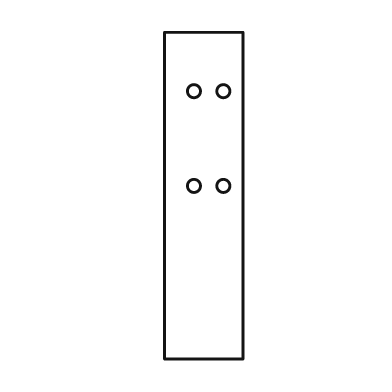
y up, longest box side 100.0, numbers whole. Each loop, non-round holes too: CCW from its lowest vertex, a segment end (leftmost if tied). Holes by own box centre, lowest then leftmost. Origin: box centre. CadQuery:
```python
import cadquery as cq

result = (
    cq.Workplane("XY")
    .moveTo(-12.0, -50.0)
    .lineTo(12.0, -50.0)
    .lineTo(12.0, 50.0)
    .lineTo(-12.0, 50.0)
    .close()
    .moveTo(-3.0, 3.0)
    .circle(2.0)
    .moveTo(6.0, 3.0)
    .circle(2.0)
    .moveTo(-3.0, 32.0)
    .circle(2.0)
    .moveTo(6.0, 32.0)
    .circle(2.0)
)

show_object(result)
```